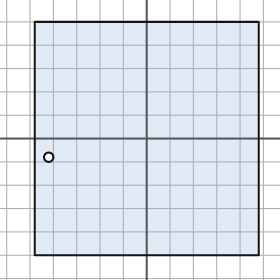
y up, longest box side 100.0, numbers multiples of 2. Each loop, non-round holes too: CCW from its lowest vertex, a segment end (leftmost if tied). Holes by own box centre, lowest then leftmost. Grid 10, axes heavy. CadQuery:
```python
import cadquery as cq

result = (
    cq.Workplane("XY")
    .moveTo(-48.0, -50.0)
    .lineTo(48.0, -50.0)
    .lineTo(48.0, 50.0)
    .lineTo(-48.0, 50.0)
    .close()
    .moveTo(-42.0, -8.0)
    .circle(2.0)
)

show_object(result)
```